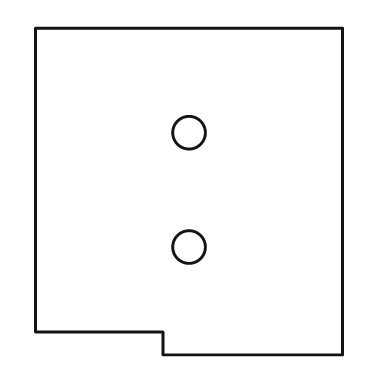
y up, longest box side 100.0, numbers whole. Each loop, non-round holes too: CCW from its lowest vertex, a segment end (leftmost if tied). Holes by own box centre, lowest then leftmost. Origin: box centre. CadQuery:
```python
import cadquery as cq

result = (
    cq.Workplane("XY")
    .moveTo(-8.0, -50.0)
    .lineTo(47.0, -50.0)
    .lineTo(47.0, 50.0)
    .lineTo(-47.0, 50.0)
    .lineTo(-47.0, -43.0)
    .lineTo(-8.0, -43.0)
    .close()
    .moveTo(0.0, -17.0)
    .circle(5.0)
    .moveTo(0.0, 18.0)
    .circle(5.0)
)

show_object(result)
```